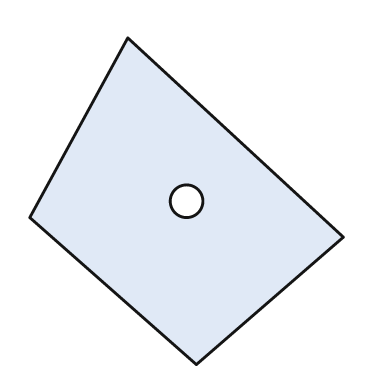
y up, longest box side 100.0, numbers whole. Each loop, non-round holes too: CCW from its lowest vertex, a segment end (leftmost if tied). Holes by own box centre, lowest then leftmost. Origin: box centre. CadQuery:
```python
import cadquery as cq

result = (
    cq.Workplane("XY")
    .moveTo(3.0, -50.0)
    .lineTo(48.0, -11.0)
    .lineTo(-18.0, 50.0)
    .lineTo(-48.0, -5.0)
    .close()
    .moveTo(0.0, 0.0)
    .circle(5.0)
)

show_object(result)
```